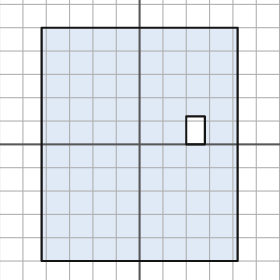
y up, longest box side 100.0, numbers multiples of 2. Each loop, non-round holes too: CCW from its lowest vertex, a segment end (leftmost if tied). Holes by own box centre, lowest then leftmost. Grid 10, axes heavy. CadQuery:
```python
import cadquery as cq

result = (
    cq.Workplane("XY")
    .moveTo(-42.0, -50.0)
    .lineTo(42.0, -50.0)
    .lineTo(42.0, 50.0)
    .lineTo(-42.0, 50.0)
    .close()
    .moveTo(20.0, 0.0)
    .lineTo(28.0, 0.0)
    .lineTo(28.0, 12.0)
    .lineTo(20.0, 12.0)
    .close()
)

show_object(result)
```